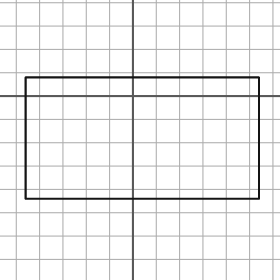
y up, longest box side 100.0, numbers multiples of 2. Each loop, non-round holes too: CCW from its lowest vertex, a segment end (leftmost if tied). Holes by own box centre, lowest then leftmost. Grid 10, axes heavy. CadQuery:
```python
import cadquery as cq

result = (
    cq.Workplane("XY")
    .moveTo(-46.0, -44.0)
    .lineTo(54.0, -44.0)
    .lineTo(54.0, 8.0)
    .lineTo(-46.0, 8.0)
    .close()
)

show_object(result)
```